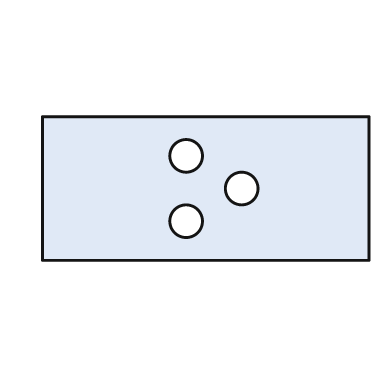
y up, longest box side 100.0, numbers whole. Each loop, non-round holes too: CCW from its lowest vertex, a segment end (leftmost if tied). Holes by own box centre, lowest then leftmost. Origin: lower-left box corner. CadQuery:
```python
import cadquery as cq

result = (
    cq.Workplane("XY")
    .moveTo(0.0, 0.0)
    .lineTo(100.0, 0.0)
    .lineTo(100.0, 44.0)
    .lineTo(0.0, 44.0)
    .close()
    .moveTo(44.0, 12.0)
    .circle(5.0)
    .moveTo(61.0, 22.0)
    .circle(5.0)
    .moveTo(44.0, 32.0)
    .circle(5.0)
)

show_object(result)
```